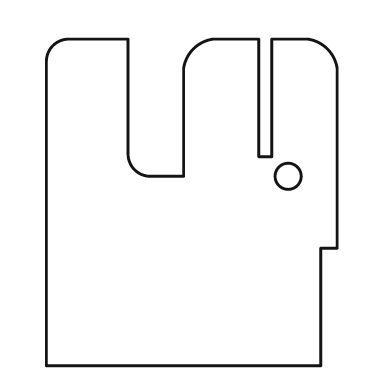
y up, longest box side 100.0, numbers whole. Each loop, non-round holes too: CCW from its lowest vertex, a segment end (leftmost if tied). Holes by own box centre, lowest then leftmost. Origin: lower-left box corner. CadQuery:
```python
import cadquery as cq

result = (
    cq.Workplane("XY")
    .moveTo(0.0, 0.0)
    .lineTo(84.0, 0.0)
    .lineTo(84.0, 36.0)
    .lineTo(89.0, 36.0)
    .lineTo(89.0, 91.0)
    .threePointArc((86.0, 97.0), (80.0, 100.0))
    .lineTo(69.0, 100.0)
    .lineTo(69.0, 64.0)
    .lineTo(65.0, 64.0)
    .lineTo(65.0, 100.0)
    .lineTo(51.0, 100.0)
    .threePointArc((45.0, 97.0), (42.0, 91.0))
    .lineTo(42.0, 58.0)
    .lineTo(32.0, 58.0)
    .threePointArc((27.0, 60.0), (25.0, 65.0))
    .lineTo(25.0, 100.0)
    .lineTo(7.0, 100.0)
    .threePointArc((2.0, 98.0), (0.0, 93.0))
    .close()
    .moveTo(74.0, 58.0)
    .circle(4.0)
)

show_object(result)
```